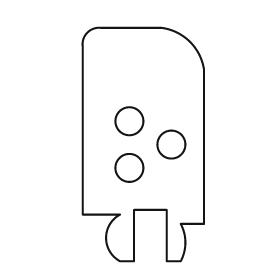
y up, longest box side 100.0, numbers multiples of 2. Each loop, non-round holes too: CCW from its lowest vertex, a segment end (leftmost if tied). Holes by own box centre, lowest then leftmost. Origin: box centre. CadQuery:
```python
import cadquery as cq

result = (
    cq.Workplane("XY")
    .moveTo(-10.0, -50.0)
    .lineTo(-4.0, -50.0)
    .lineTo(-4.0, -28.0)
    .lineTo(10.0, -28.0)
    .lineTo(10.0, -50.0)
    .lineTo(16.0, -50.0)
    .threePointArc((18.0, -42.0), (16.0, -34.0))
    .lineTo(26.0, -34.0)
    .lineTo(26.0, 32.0)
    .threePointArc((20.0, 44.0), (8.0, 50.0))
    .lineTo(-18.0, 50.0)
    .threePointArc((-24.0, 48.0), (-26.0, 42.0))
    .lineTo(-26.0, -30.0)
    .lineTo(-10.0, -30.0)
    .threePointArc((-16.0, -40.0), (-10.0, -50.0))
    .close()
    .moveTo(-6.0, -10.0)
    .circle(6.0)
    .moveTo(12.0, 0.0)
    .circle(6.0)
    .moveTo(-6.0, 10.0)
    .circle(6.0)
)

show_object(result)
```